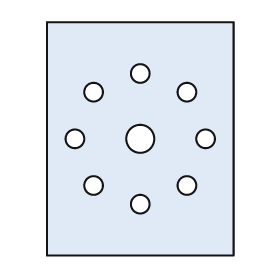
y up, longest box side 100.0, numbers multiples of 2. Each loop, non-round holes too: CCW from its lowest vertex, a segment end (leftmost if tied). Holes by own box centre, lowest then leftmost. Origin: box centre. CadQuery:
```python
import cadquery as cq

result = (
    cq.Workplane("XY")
    .moveTo(-40.0, -50.0)
    .lineTo(40.0, -50.0)
    .lineTo(40.0, 50.0)
    .lineTo(-40.0, 50.0)
    .close()
    .moveTo(0.0, -28.0)
    .circle(4.0)
    .moveTo(-20.0, -20.0)
    .circle(4.0)
    .moveTo(20.0, -20.0)
    .circle(4.0)
    .moveTo(-28.0, 0.0)
    .circle(4.0)
    .moveTo(0.0, 0.0)
    .circle(6.0)
    .moveTo(28.0, 0.0)
    .circle(4.0)
    .moveTo(-20.0, 20.0)
    .circle(4.0)
    .moveTo(20.0, 20.0)
    .circle(4.0)
    .moveTo(0.0, 28.0)
    .circle(4.0)
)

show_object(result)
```